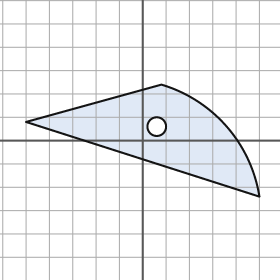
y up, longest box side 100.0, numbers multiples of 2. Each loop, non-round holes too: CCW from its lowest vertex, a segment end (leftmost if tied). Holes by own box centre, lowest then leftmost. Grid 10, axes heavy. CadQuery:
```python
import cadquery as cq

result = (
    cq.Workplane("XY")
    .moveTo(50.0, -24.0)
    .threePointArc((36.0, 6.0), (8.0, 24.0))
    .lineTo(-50.0, 8.0)
    .close()
    .moveTo(6.0, 6.0)
    .circle(4.0)
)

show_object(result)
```